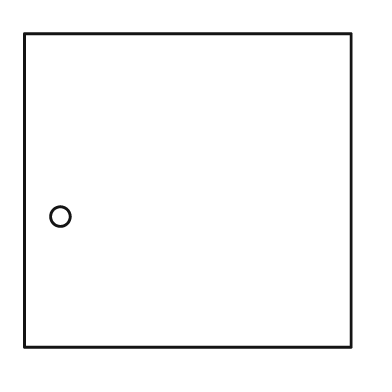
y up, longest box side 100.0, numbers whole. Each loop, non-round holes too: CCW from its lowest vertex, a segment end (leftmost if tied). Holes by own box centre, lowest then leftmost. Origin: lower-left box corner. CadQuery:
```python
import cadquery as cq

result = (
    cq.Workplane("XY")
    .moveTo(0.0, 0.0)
    .lineTo(100.0, 0.0)
    .lineTo(100.0, 96.0)
    .lineTo(0.0, 96.0)
    .close()
    .moveTo(11.0, 40.0)
    .circle(3.0)
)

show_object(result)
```